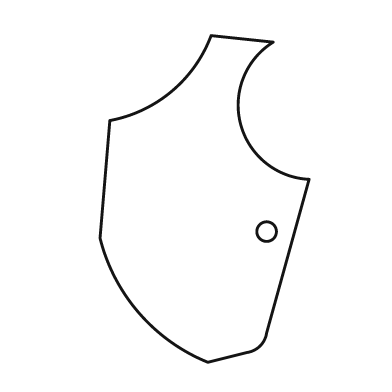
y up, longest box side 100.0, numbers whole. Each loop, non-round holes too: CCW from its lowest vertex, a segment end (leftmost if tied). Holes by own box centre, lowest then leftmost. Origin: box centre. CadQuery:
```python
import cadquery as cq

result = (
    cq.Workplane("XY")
    .moveTo(1.0, -50.0)
    .lineTo(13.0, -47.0)
    .threePointArc((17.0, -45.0), (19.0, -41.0))
    .lineTo(32.0, 6.0)
    .threePointArc((11.0, 23.0), (21.0, 48.0))
    .lineTo(2.0, 50.0)
    .threePointArc((-10.0, 33.0), (-29.0, 24.0))
    .lineTo(-32.0, -12.0)
    .threePointArc((-20.0, -35.0), (1.0, -50.0))
    .close()
    .moveTo(19.0, -10.0)
    .circle(3.0)
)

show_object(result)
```